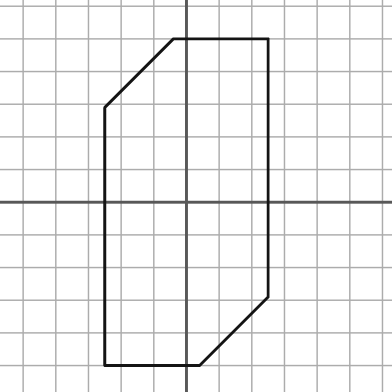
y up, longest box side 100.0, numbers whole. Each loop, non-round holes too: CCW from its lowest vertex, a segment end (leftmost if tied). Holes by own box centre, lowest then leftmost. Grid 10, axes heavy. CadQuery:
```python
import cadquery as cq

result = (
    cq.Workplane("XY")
    .moveTo(-25.0, -50.0)
    .lineTo(4.0, -50.0)
    .lineTo(25.0, -29.0)
    .lineTo(25.0, 50.0)
    .lineTo(-4.0, 50.0)
    .lineTo(-25.0, 29.0)
    .close()
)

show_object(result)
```